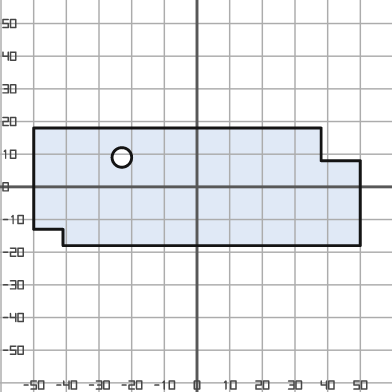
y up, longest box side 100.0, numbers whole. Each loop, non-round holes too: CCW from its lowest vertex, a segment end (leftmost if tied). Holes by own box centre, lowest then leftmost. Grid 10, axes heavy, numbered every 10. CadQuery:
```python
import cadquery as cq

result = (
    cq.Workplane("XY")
    .moveTo(-41.0, -18.0)
    .lineTo(50.0, -18.0)
    .lineTo(50.0, 8.0)
    .lineTo(38.0, 8.0)
    .lineTo(38.0, 18.0)
    .lineTo(-50.0, 18.0)
    .lineTo(-50.0, -13.0)
    .lineTo(-41.0, -13.0)
    .close()
    .moveTo(-23.0, 9.0)
    .circle(3.0)
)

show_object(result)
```